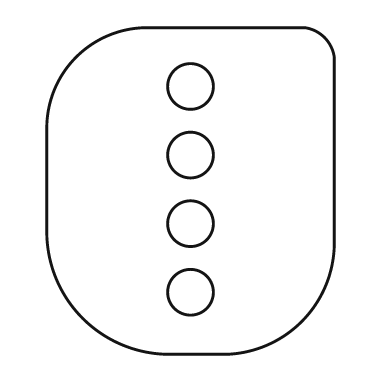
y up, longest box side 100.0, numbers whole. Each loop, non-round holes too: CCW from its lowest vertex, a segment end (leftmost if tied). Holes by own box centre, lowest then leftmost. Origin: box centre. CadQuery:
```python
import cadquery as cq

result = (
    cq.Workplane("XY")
    .moveTo(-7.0, -50.0)
    .lineTo(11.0, -50.0)
    .threePointArc((34.0, -40.0), (44.0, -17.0))
    .lineTo(44.0, 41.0)
    .threePointArc((41.0, 47.0), (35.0, 50.0))
    .lineTo(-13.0, 50.0)
    .threePointArc((-35.0, 41.0), (-44.0, 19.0))
    .lineTo(-44.0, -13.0)
    .threePointArc((-33.0, -39.0), (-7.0, -50.0))
    .close()
    .moveTo(0.0, -31.0)
    .circle(7.0)
    .moveTo(0.0, -10.0)
    .circle(7.0)
    .moveTo(0.0, 11.0)
    .circle(7.0)
    .moveTo(0.0, 32.0)
    .circle(7.0)
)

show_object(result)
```